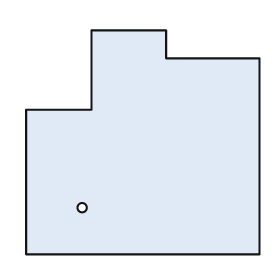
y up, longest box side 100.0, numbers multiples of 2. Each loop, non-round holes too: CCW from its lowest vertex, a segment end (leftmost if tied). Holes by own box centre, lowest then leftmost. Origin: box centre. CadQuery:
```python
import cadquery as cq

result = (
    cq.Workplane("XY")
    .moveTo(-50.0, -48.0)
    .lineTo(50.0, -48.0)
    .lineTo(50.0, 36.0)
    .lineTo(10.0, 36.0)
    .lineTo(10.0, 48.0)
    .lineTo(-22.0, 48.0)
    .lineTo(-22.0, 14.0)
    .lineTo(-50.0, 14.0)
    .close()
    .moveTo(-26.0, -28.0)
    .circle(2.0)
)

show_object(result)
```